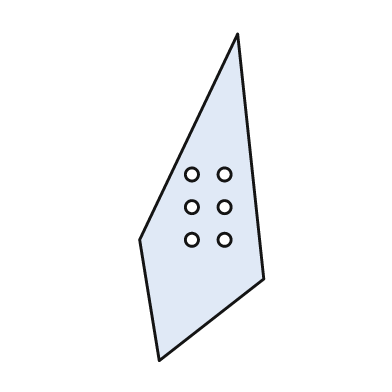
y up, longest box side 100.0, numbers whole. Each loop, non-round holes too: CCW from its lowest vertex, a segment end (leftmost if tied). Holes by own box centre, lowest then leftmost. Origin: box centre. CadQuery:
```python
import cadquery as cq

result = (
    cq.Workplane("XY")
    .moveTo(-13.0, -50.0)
    .lineTo(19.0, -25.0)
    .lineTo(11.0, 50.0)
    .lineTo(-19.0, -13.0)
    .close()
    .moveTo(-3.0, -13.0)
    .circle(2.0)
    .moveTo(7.0, -13.0)
    .circle(2.0)
    .moveTo(-3.0, -3.0)
    .circle(2.0)
    .moveTo(7.0, -3.0)
    .circle(2.0)
    .moveTo(-3.0, 7.0)
    .circle(2.0)
    .moveTo(7.0, 7.0)
    .circle(2.0)
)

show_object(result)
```